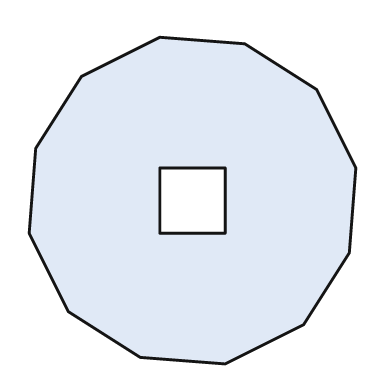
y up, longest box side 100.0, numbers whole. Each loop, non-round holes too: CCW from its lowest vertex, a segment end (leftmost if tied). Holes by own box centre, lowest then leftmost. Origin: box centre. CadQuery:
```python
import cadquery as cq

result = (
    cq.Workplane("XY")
    .moveTo(10.0, -50.0)
    .lineTo(34.0, -38.0)
    .lineTo(48.0, -16.0)
    .lineTo(50.0, 10.0)
    .lineTo(38.0, 34.0)
    .lineTo(16.0, 48.0)
    .lineTo(-10.0, 50.0)
    .lineTo(-34.0, 38.0)
    .lineTo(-48.0, 16.0)
    .lineTo(-50.0, -10.0)
    .lineTo(-38.0, -34.0)
    .lineTo(-16.0, -48.0)
    .close()
    .moveTo(-10.0, -10.0)
    .lineTo(10.0, -10.0)
    .lineTo(10.0, 10.0)
    .lineTo(-10.0, 10.0)
    .close()
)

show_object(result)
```